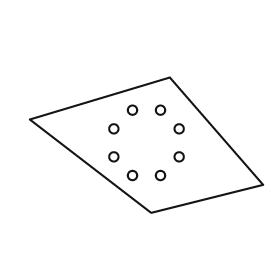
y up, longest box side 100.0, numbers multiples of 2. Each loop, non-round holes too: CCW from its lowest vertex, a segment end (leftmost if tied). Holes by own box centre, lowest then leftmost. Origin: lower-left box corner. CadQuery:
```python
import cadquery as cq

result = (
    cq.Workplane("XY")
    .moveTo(52.0, 0.0)
    .lineTo(100.0, 12.0)
    .lineTo(60.0, 58.0)
    .lineTo(0.0, 40.0)
    .close()
    .moveTo(44.0, 16.0)
    .circle(2.0)
    .moveTo(56.0, 16.0)
    .circle(2.0)
    .moveTo(36.0, 24.0)
    .circle(2.0)
    .moveTo(64.0, 24.0)
    .circle(2.0)
    .moveTo(36.0, 36.0)
    .circle(2.0)
    .moveTo(64.0, 36.0)
    .circle(2.0)
    .moveTo(44.0, 44.0)
    .circle(2.0)
    .moveTo(56.0, 44.0)
    .circle(2.0)
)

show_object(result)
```